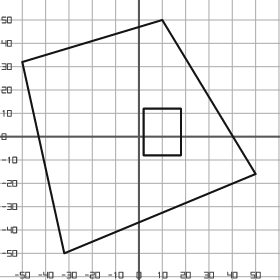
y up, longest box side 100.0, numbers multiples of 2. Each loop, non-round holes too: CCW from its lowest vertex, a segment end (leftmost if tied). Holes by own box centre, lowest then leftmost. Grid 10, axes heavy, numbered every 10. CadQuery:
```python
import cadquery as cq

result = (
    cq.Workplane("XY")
    .moveTo(-32.0, -50.0)
    .lineTo(50.0, -16.0)
    .lineTo(10.0, 50.0)
    .lineTo(-50.0, 32.0)
    .close()
    .moveTo(2.0, -8.0)
    .lineTo(18.0, -8.0)
    .lineTo(18.0, 12.0)
    .lineTo(2.0, 12.0)
    .close()
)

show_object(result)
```